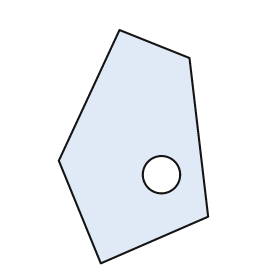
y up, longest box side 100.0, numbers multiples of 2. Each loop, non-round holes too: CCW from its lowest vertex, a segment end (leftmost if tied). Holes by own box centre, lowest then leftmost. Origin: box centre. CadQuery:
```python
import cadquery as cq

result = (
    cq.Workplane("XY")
    .moveTo(-14.0, -50.0)
    .lineTo(32.0, -30.0)
    .lineTo(24.0, 38.0)
    .lineTo(-6.0, 50.0)
    .lineTo(-32.0, -6.0)
    .close()
    .moveTo(12.0, -12.0)
    .circle(8.0)
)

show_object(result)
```